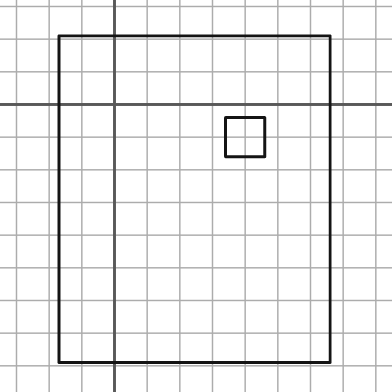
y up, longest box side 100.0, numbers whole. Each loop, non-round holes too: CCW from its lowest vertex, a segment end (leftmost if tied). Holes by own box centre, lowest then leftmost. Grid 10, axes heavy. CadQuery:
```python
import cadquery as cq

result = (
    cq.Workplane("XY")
    .moveTo(-17.0, -79.0)
    .lineTo(66.0, -79.0)
    .lineTo(66.0, 21.0)
    .lineTo(-17.0, 21.0)
    .close()
    .moveTo(34.0, -16.0)
    .lineTo(46.0, -16.0)
    .lineTo(46.0, -4.0)
    .lineTo(34.0, -4.0)
    .close()
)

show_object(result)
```